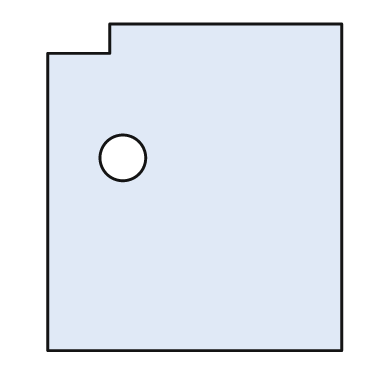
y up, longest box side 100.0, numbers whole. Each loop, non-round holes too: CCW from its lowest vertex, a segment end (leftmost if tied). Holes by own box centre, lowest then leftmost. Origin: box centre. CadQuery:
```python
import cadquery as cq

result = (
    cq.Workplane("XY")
    .moveTo(-45.0, -50.0)
    .lineTo(45.0, -50.0)
    .lineTo(45.0, 50.0)
    .lineTo(-26.0, 50.0)
    .lineTo(-26.0, 41.0)
    .lineTo(-45.0, 41.0)
    .close()
    .moveTo(-22.0, 9.0)
    .circle(7.0)
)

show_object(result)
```